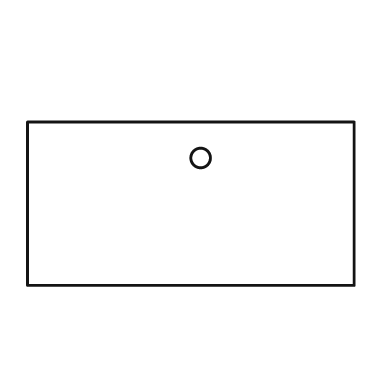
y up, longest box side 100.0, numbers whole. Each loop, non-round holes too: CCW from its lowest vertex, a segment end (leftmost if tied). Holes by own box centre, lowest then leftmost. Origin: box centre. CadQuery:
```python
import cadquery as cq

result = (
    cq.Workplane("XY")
    .moveTo(-50.0, -25.0)
    .lineTo(50.0, -25.0)
    .lineTo(50.0, 25.0)
    .lineTo(-50.0, 25.0)
    .close()
    .moveTo(3.0, 14.0)
    .circle(3.0)
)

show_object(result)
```